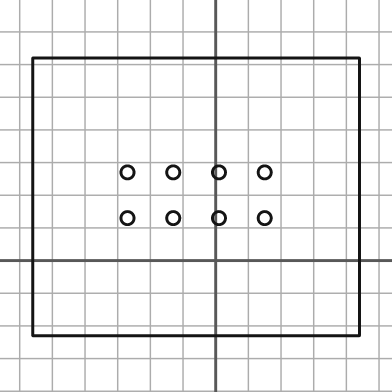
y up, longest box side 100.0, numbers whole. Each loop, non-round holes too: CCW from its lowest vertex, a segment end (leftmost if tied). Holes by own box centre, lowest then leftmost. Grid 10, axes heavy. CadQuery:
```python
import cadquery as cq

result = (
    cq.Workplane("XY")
    .moveTo(-56.0, -23.0)
    .lineTo(44.0, -23.0)
    .lineTo(44.0, 62.0)
    .lineTo(-56.0, 62.0)
    .close()
    .moveTo(-27.0, 13.0)
    .circle(2.0)
    .moveTo(-13.0, 13.0)
    .circle(2.0)
    .moveTo(1.0, 13.0)
    .circle(2.0)
    .moveTo(15.0, 13.0)
    .circle(2.0)
    .moveTo(-27.0, 27.0)
    .circle(2.0)
    .moveTo(-13.0, 27.0)
    .circle(2.0)
    .moveTo(1.0, 27.0)
    .circle(2.0)
    .moveTo(15.0, 27.0)
    .circle(2.0)
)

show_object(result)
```